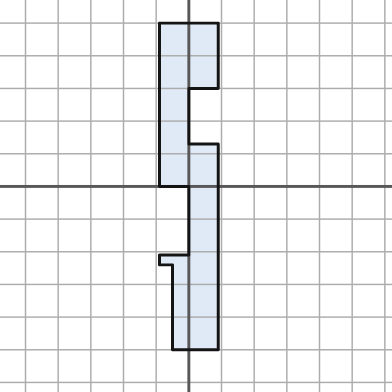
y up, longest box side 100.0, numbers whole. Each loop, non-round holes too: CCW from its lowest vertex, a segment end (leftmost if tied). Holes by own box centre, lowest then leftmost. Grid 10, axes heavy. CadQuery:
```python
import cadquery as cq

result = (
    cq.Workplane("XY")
    .moveTo(-5.0, -50.0)
    .lineTo(9.0, -50.0)
    .lineTo(9.0, 13.0)
    .lineTo(0.0, 13.0)
    .lineTo(0.0, 30.0)
    .lineTo(9.0, 30.0)
    .lineTo(9.0, 50.0)
    .lineTo(-9.0, 50.0)
    .lineTo(-9.0, 0.0)
    .lineTo(0.0, 0.0)
    .lineTo(0.0, -21.0)
    .lineTo(-9.0, -21.0)
    .lineTo(-9.0, -24.0)
    .lineTo(-5.0, -24.0)
    .close()
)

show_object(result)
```